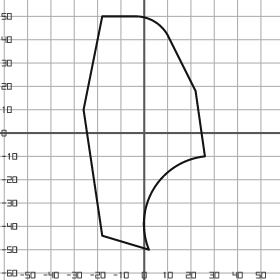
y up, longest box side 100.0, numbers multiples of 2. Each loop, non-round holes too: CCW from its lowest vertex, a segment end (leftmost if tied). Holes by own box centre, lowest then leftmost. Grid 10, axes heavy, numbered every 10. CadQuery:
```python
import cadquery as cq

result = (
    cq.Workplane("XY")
    .moveTo(2.0, -50.0)
    .threePointArc((4.0, -24.0), (26.0, -10.0))
    .lineTo(22.0, 18.0)
    .lineTo(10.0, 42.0)
    .threePointArc((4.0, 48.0), (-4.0, 50.0))
    .lineTo(-18.0, 50.0)
    .lineTo(-26.0, 10.0)
    .lineTo(-18.0, -44.0)
    .close()
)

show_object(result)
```